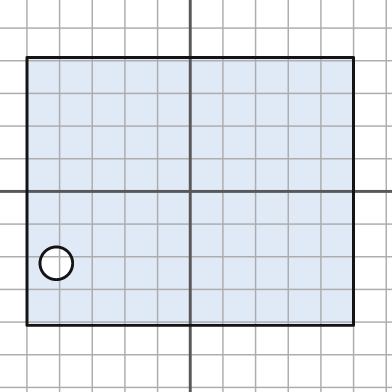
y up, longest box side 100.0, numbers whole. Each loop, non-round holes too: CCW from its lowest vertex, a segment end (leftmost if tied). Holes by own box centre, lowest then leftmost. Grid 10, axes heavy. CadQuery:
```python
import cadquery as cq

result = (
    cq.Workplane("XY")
    .moveTo(-50.0, -41.0)
    .lineTo(50.0, -41.0)
    .lineTo(50.0, 41.0)
    .lineTo(-50.0, 41.0)
    .close()
    .moveTo(-41.0, -22.0)
    .circle(5.0)
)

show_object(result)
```